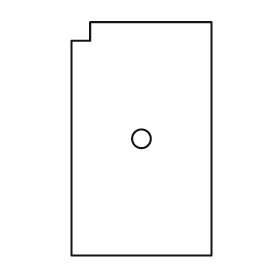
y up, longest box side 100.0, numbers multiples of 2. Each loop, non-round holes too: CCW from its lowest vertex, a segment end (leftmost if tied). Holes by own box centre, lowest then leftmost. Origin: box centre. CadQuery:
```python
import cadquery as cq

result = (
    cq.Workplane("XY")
    .moveTo(-30.0, -50.0)
    .lineTo(30.0, -50.0)
    .lineTo(30.0, 50.0)
    .lineTo(-22.0, 50.0)
    .lineTo(-22.0, 42.0)
    .lineTo(-30.0, 42.0)
    .close()
    .moveTo(0.0, 0.0)
    .circle(4.0)
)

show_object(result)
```